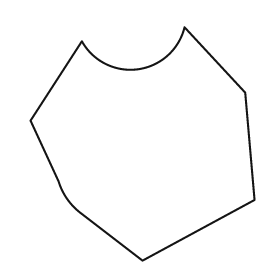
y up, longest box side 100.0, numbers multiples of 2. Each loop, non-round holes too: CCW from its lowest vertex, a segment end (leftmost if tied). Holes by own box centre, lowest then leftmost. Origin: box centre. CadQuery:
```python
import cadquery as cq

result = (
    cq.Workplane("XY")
    .moveTo(0.0, -50.0)
    .lineTo(48.0, -24.0)
    .lineTo(44.0, 22.0)
    .lineTo(18.0, 50.0)
    .threePointArc((-2.0, 32.0), (-26.0, 44.0))
    .lineTo(-48.0, 10.0)
    .lineTo(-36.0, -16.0)
    .threePointArc((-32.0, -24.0), (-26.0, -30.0))
    .close()
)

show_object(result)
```